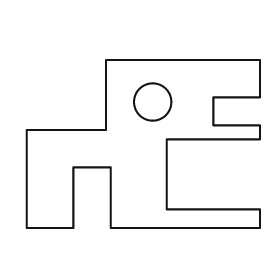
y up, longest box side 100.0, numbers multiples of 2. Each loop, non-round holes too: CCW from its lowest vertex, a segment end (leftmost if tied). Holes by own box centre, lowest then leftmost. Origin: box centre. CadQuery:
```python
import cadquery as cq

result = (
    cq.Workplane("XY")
    .moveTo(-50.0, -36.0)
    .lineTo(-30.0, -36.0)
    .lineTo(-30.0, -10.0)
    .lineTo(-14.0, -10.0)
    .lineTo(-14.0, -36.0)
    .lineTo(50.0, -36.0)
    .lineTo(50.0, -28.0)
    .lineTo(10.0, -28.0)
    .lineTo(10.0, 2.0)
    .lineTo(50.0, 2.0)
    .lineTo(50.0, 8.0)
    .lineTo(30.0, 8.0)
    .lineTo(30.0, 20.0)
    .lineTo(50.0, 20.0)
    .lineTo(50.0, 36.0)
    .lineTo(-16.0, 36.0)
    .lineTo(-16.0, 6.0)
    .lineTo(-50.0, 6.0)
    .close()
    .moveTo(4.0, 18.0)
    .circle(8.0)
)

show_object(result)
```